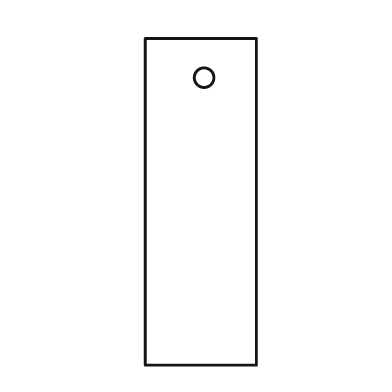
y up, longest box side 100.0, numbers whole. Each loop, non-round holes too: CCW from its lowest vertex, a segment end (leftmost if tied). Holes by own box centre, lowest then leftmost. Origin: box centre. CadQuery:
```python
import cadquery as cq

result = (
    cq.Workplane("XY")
    .moveTo(-17.0, -50.0)
    .lineTo(17.0, -50.0)
    .lineTo(17.0, 50.0)
    .lineTo(-17.0, 50.0)
    .close()
    .moveTo(1.0, 38.0)
    .circle(3.0)
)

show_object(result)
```